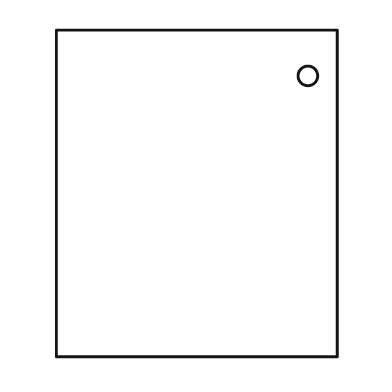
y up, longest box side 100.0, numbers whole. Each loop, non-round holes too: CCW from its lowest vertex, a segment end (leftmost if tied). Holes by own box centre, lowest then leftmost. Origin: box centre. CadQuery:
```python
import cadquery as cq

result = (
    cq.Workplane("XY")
    .moveTo(-43.0, -50.0)
    .lineTo(43.0, -50.0)
    .lineTo(43.0, 50.0)
    .lineTo(-43.0, 50.0)
    .close()
    .moveTo(34.0, 36.0)
    .circle(3.0)
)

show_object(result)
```